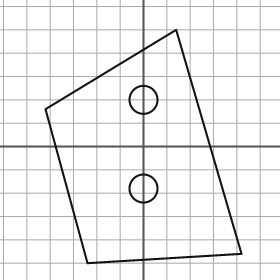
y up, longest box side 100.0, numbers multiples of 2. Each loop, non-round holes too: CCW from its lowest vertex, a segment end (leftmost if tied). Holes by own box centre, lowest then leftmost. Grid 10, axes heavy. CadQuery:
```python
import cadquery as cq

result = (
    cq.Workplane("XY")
    .moveTo(-24.0, -50.0)
    .lineTo(42.0, -46.0)
    .lineTo(14.0, 50.0)
    .lineTo(-42.0, 16.0)
    .close()
    .moveTo(0.0, -18.0)
    .circle(6.0)
    .moveTo(0.0, 20.0)
    .circle(6.0)
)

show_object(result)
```